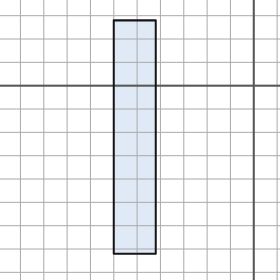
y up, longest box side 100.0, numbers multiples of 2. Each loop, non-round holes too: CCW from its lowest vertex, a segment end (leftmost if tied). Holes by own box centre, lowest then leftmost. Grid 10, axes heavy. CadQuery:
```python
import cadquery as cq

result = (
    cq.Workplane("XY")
    .moveTo(-60.0, -72.0)
    .lineTo(-42.0, -72.0)
    .lineTo(-42.0, 28.0)
    .lineTo(-60.0, 28.0)
    .close()
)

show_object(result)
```